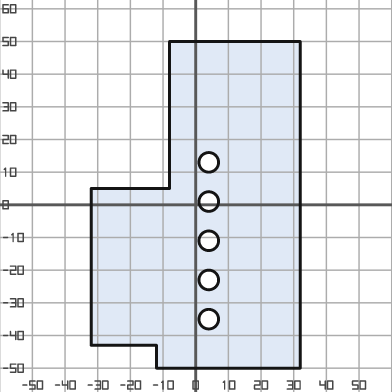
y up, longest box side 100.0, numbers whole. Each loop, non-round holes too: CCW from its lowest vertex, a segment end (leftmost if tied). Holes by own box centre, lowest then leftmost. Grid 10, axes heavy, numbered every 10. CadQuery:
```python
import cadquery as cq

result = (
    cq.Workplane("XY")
    .moveTo(-12.0, -50.0)
    .lineTo(32.0, -50.0)
    .lineTo(32.0, 50.0)
    .lineTo(-8.0, 50.0)
    .lineTo(-8.0, 5.0)
    .lineTo(-32.0, 5.0)
    .lineTo(-32.0, -43.0)
    .lineTo(-12.0, -43.0)
    .close()
    .moveTo(4.0, -35.0)
    .circle(3.0)
    .moveTo(4.0, -23.0)
    .circle(3.0)
    .moveTo(4.0, -11.0)
    .circle(3.0)
    .moveTo(4.0, 1.0)
    .circle(3.0)
    .moveTo(4.0, 13.0)
    .circle(3.0)
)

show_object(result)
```